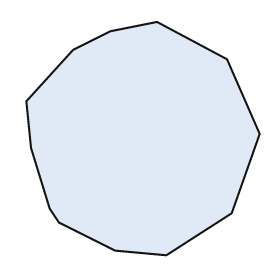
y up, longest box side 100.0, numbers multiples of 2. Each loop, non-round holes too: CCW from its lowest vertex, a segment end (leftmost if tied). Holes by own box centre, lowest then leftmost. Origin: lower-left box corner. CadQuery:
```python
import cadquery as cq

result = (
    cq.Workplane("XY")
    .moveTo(60.0, 0.0)
    .lineTo(88.0, 18.0)
    .lineTo(100.0, 52.0)
    .lineTo(86.0, 84.0)
    .lineTo(56.0, 100.0)
    .lineTo(36.0, 96.0)
    .lineTo(20.0, 88.0)
    .lineTo(0.0, 66.0)
    .lineTo(2.0, 46.0)
    .lineTo(10.0, 20.0)
    .lineTo(14.0, 14.0)
    .lineTo(38.0, 2.0)
    .close()
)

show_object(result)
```